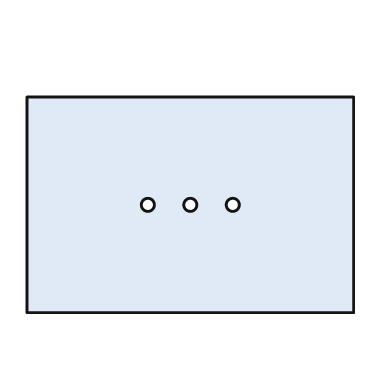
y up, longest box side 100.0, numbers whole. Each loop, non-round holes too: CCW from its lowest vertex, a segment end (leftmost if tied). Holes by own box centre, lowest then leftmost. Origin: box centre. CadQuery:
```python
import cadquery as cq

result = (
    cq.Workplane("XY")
    .moveTo(-50.0, -33.0)
    .lineTo(50.0, -33.0)
    .lineTo(50.0, 33.0)
    .lineTo(-50.0, 33.0)
    .close()
    .moveTo(-13.0, 0.0)
    .circle(2.0)
    .moveTo(0.0, 0.0)
    .circle(2.0)
    .moveTo(13.0, 0.0)
    .circle(2.0)
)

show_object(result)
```